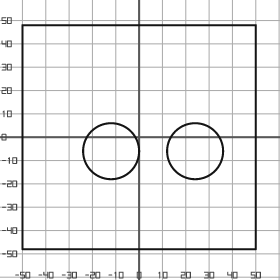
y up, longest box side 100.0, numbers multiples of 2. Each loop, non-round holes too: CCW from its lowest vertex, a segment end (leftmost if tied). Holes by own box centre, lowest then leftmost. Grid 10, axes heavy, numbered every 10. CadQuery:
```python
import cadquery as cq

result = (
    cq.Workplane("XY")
    .moveTo(-50.0, -48.0)
    .lineTo(50.0, -48.0)
    .lineTo(50.0, 48.0)
    .lineTo(-50.0, 48.0)
    .close()
    .moveTo(-12.0, -6.0)
    .circle(12.0)
    .moveTo(24.0, -6.0)
    .circle(12.0)
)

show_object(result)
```